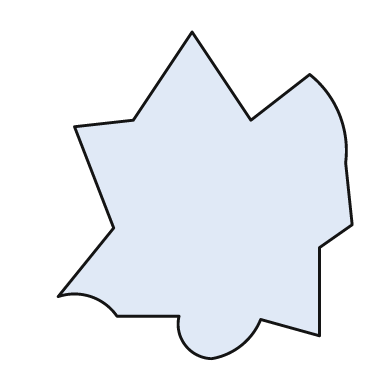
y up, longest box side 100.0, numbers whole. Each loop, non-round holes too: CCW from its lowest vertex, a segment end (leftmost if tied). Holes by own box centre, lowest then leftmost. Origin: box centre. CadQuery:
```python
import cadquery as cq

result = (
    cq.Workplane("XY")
    .moveTo(2.0, -50.0)
    .threePointArc((11.0, -46.0), (17.0, -38.0))
    .lineTo(35.0, -43.0)
    .lineTo(35.0, -16.0)
    .lineTo(45.0, -9.0)
    .lineTo(43.0, 10.0)
    .threePointArc((41.0, 25.0), (32.0, 37.0))
    .lineTo(14.0, 23.0)
    .lineTo(-4.0, 50.0)
    .lineTo(-22.0, 23.0)
    .lineTo(-40.0, 21.0)
    .lineTo(-28.0, -10.0)
    .lineTo(-45.0, -31.0)
    .threePointArc((-35.0, -31.0), (-27.0, -37.0))
    .lineTo(-8.0, -37.0)
    .threePointArc((-6.0, -46.0), (2.0, -50.0))
    .close()
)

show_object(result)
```